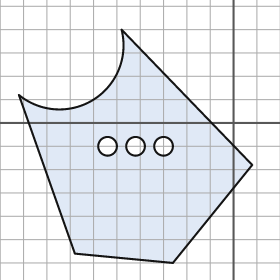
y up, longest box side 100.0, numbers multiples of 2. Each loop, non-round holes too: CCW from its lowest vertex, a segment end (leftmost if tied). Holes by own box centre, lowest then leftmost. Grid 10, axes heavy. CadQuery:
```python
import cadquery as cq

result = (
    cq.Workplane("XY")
    .moveTo(-26.0, -60.0)
    .lineTo(8.0, -18.0)
    .lineTo(-48.0, 40.0)
    .threePointArc((-60.0, 10.0), (-92.0, 12.0))
    .lineTo(-68.0, -56.0)
    .close()
    .moveTo(-54.0, -10.0)
    .circle(4.0)
    .moveTo(-42.0, -10.0)
    .circle(4.0)
    .moveTo(-30.0, -10.0)
    .circle(4.0)
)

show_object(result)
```